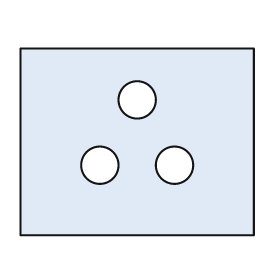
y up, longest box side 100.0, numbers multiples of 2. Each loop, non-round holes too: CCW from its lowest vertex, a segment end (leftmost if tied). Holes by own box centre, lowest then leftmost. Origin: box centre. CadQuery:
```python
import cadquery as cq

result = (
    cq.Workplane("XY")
    .moveTo(-50.0, -40.0)
    .lineTo(50.0, -40.0)
    .lineTo(50.0, 40.0)
    .lineTo(-50.0, 40.0)
    .close()
    .moveTo(-16.0, -10.0)
    .circle(8.0)
    .moveTo(16.0, -10.0)
    .circle(8.0)
    .moveTo(0.0, 18.0)
    .circle(8.0)
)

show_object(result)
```